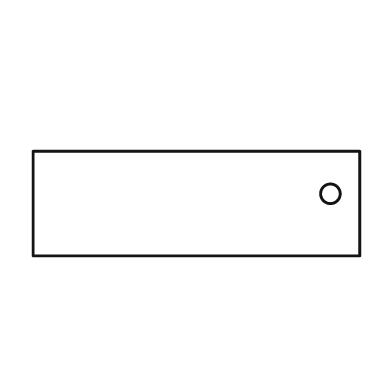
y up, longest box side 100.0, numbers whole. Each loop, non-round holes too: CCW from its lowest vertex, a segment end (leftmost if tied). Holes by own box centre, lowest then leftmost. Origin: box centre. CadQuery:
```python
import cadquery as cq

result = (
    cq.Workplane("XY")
    .moveTo(-50.0, -16.0)
    .lineTo(50.0, -16.0)
    .lineTo(50.0, 16.0)
    .lineTo(-50.0, 16.0)
    .close()
    .moveTo(41.0, 3.0)
    .circle(3.0)
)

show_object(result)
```